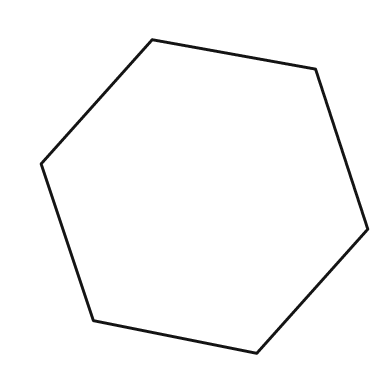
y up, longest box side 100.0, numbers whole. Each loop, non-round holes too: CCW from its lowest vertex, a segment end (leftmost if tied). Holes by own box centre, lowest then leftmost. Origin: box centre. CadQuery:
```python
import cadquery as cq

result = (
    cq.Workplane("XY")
    .moveTo(16.0, -48.0)
    .lineTo(50.0, -10.0)
    .lineTo(34.0, 39.0)
    .lineTo(-16.0, 48.0)
    .lineTo(-50.0, 10.0)
    .lineTo(-34.0, -38.0)
    .close()
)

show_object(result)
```